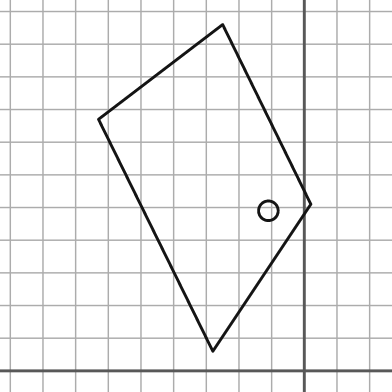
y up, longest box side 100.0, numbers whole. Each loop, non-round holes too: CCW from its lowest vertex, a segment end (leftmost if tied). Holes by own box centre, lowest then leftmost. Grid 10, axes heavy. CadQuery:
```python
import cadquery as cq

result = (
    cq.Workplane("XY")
    .moveTo(-28.0, 6.0)
    .lineTo(2.0, 51.0)
    .lineTo(-25.0, 106.0)
    .lineTo(-63.0, 77.0)
    .close()
    .moveTo(-11.0, 49.0)
    .circle(3.0)
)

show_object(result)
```